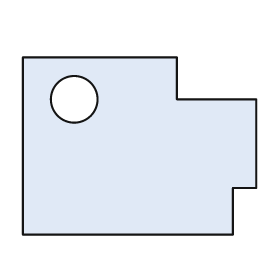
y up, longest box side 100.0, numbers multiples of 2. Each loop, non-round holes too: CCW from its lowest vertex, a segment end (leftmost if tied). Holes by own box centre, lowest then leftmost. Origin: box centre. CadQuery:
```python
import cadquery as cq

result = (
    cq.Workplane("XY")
    .moveTo(-50.0, -38.0)
    .lineTo(40.0, -38.0)
    .lineTo(40.0, -18.0)
    .lineTo(50.0, -18.0)
    .lineTo(50.0, 20.0)
    .lineTo(16.0, 20.0)
    .lineTo(16.0, 38.0)
    .lineTo(-50.0, 38.0)
    .close()
    .moveTo(-28.0, 20.0)
    .circle(10.0)
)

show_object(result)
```